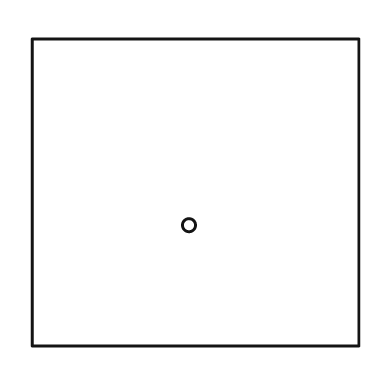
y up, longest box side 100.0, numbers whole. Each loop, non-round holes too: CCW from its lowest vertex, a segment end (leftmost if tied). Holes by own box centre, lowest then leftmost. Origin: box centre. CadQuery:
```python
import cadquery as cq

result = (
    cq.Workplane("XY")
    .moveTo(-50.0, -47.0)
    .lineTo(50.0, -47.0)
    .lineTo(50.0, 47.0)
    .lineTo(-50.0, 47.0)
    .close()
    .moveTo(-2.0, -10.0)
    .circle(2.0)
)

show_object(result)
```